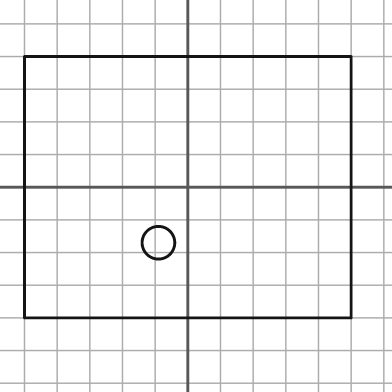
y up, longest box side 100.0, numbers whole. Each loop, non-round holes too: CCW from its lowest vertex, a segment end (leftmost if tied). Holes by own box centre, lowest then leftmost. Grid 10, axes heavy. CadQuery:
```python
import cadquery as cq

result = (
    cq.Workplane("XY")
    .moveTo(-50.0, -40.0)
    .lineTo(50.0, -40.0)
    .lineTo(50.0, 40.0)
    .lineTo(-50.0, 40.0)
    .close()
    .moveTo(-9.0, -17.0)
    .circle(5.0)
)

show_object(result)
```